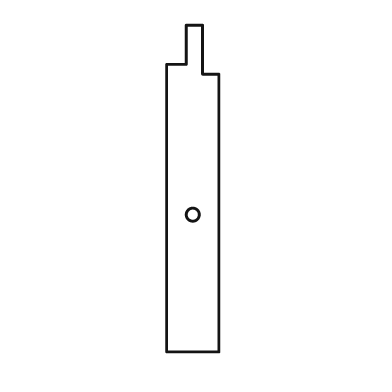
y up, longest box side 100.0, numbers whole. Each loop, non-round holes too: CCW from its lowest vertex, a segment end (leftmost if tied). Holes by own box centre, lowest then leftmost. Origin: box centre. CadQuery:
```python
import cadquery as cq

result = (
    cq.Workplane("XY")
    .moveTo(-8.0, -50.0)
    .lineTo(8.0, -50.0)
    .lineTo(8.0, 35.0)
    .lineTo(3.0, 35.0)
    .lineTo(3.0, 50.0)
    .lineTo(-2.0, 50.0)
    .lineTo(-2.0, 38.0)
    .lineTo(-8.0, 38.0)
    .close()
    .moveTo(0.0, -8.0)
    .circle(2.0)
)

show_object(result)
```